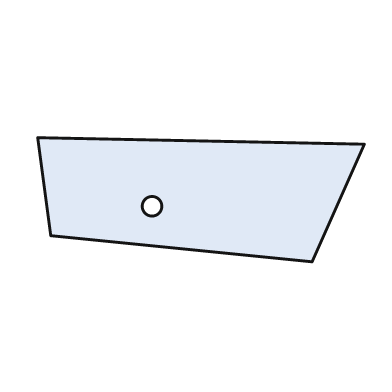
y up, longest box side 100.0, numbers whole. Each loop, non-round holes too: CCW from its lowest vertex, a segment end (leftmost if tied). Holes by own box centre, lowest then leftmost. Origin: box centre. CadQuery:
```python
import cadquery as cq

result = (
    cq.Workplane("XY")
    .moveTo(34.0, -19.0)
    .lineTo(50.0, 17.0)
    .lineTo(-50.0, 19.0)
    .lineTo(-46.0, -11.0)
    .close()
    .moveTo(-15.0, -2.0)
    .circle(3.0)
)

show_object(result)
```